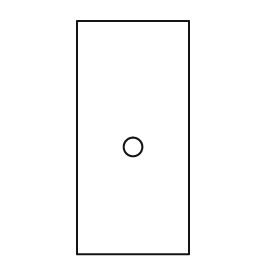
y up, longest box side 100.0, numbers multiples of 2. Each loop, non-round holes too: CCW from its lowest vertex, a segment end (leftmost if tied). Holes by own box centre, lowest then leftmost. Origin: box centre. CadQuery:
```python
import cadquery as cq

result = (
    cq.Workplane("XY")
    .moveTo(-24.0, -50.0)
    .lineTo(24.0, -50.0)
    .lineTo(24.0, 50.0)
    .lineTo(-24.0, 50.0)
    .close()
    .moveTo(0.0, -4.0)
    .circle(4.0)
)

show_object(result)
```